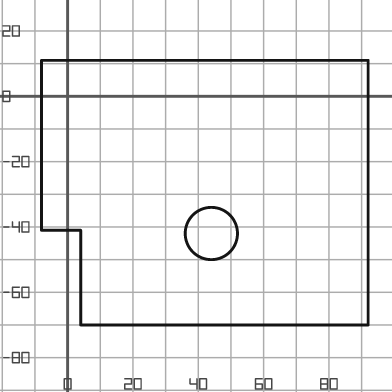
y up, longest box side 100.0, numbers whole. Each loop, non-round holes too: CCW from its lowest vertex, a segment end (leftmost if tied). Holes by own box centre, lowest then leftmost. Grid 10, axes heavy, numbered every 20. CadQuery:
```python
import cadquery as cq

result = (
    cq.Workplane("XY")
    .moveTo(4.0, -70.0)
    .lineTo(92.0, -70.0)
    .lineTo(92.0, 11.0)
    .lineTo(-8.0, 11.0)
    .lineTo(-8.0, -41.0)
    .lineTo(4.0, -41.0)
    .close()
    .moveTo(44.0, -42.0)
    .circle(8.0)
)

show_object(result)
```